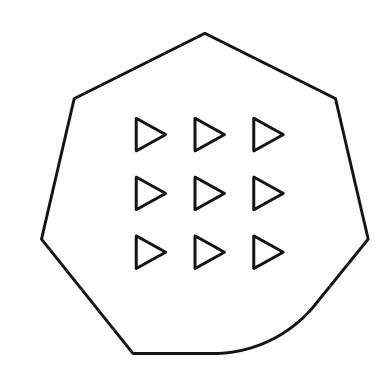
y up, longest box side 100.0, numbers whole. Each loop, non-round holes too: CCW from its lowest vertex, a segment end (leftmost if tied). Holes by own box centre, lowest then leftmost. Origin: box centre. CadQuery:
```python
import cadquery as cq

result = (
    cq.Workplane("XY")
    .moveTo(-22.0, -49.0)
    .lineTo(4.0, -49.0)
    .threePointArc((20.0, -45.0), (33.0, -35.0))
    .lineTo(50.0, -14.0)
    .lineTo(40.0, 29.0)
    .lineTo(0.0, 49.0)
    .lineTo(-40.0, 29.0)
    .lineTo(-50.0, -14.0)
    .close()
    .moveTo(-21.0, -23.0)
    .lineTo(-12.0, -18.0)
    .lineTo(-21.0, -13.0)
    .close()
    .moveTo(-3.0, -23.0)
    .lineTo(6.0, -18.0)
    .lineTo(-3.0, -13.0)
    .close()
    .moveTo(15.0, -23.0)
    .lineTo(24.0, -18.0)
    .lineTo(15.0, -13.0)
    .close()
    .moveTo(-21.0, -5.0)
    .lineTo(-12.0, 0.0)
    .lineTo(-21.0, 5.0)
    .close()
    .moveTo(-3.0, -5.0)
    .lineTo(6.0, 0.0)
    .lineTo(-3.0, 5.0)
    .close()
    .moveTo(15.0, -5.0)
    .lineTo(24.0, 0.0)
    .lineTo(15.0, 5.0)
    .close()
    .moveTo(-21.0, 13.0)
    .lineTo(-12.0, 18.0)
    .lineTo(-21.0, 23.0)
    .close()
    .moveTo(-3.0, 13.0)
    .lineTo(6.0, 18.0)
    .lineTo(-3.0, 23.0)
    .close()
    .moveTo(15.0, 13.0)
    .lineTo(24.0, 18.0)
    .lineTo(15.0, 23.0)
    .close()
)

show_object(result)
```